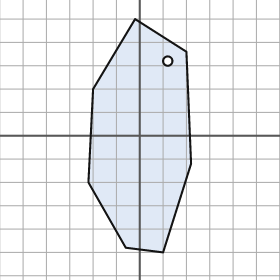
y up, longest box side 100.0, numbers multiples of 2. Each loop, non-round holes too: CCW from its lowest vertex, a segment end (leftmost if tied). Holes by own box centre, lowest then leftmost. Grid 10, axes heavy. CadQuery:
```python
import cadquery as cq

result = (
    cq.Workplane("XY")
    .moveTo(10.0, -50.0)
    .lineTo(22.0, -12.0)
    .lineTo(20.0, 36.0)
    .lineTo(-2.0, 50.0)
    .lineTo(-20.0, 20.0)
    .lineTo(-22.0, -20.0)
    .lineTo(-6.0, -48.0)
    .close()
    .moveTo(12.0, 32.0)
    .circle(2.0)
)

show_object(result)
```